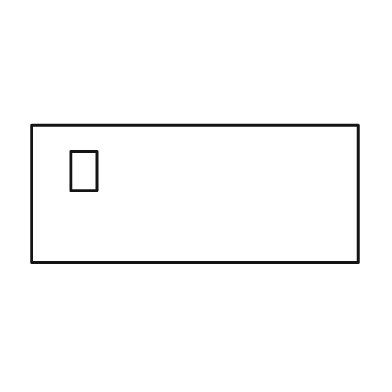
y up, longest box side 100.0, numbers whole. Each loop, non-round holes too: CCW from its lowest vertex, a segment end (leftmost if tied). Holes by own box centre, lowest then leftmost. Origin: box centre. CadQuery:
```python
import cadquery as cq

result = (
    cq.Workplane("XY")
    .moveTo(-50.0, -21.0)
    .lineTo(50.0, -21.0)
    .lineTo(50.0, 21.0)
    .lineTo(-50.0, 21.0)
    .close()
    .moveTo(-38.0, 1.0)
    .lineTo(-30.0, 1.0)
    .lineTo(-30.0, 13.0)
    .lineTo(-38.0, 13.0)
    .close()
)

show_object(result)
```